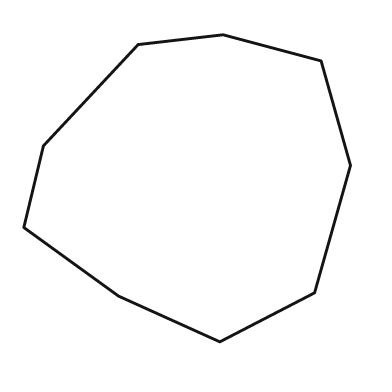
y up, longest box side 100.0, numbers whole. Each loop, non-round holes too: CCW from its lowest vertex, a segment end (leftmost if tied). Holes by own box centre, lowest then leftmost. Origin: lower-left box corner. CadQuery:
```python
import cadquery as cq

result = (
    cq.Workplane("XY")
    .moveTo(60.0, 0.0)
    .lineTo(89.0, 15.0)
    .lineTo(100.0, 54.0)
    .lineTo(91.0, 86.0)
    .lineTo(61.0, 94.0)
    .lineTo(35.0, 91.0)
    .lineTo(6.0, 60.0)
    .lineTo(0.0, 35.0)
    .lineTo(29.0, 14.0)
    .close()
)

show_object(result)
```